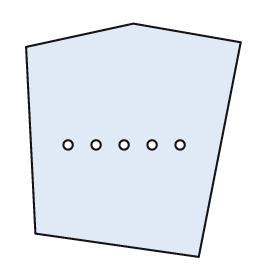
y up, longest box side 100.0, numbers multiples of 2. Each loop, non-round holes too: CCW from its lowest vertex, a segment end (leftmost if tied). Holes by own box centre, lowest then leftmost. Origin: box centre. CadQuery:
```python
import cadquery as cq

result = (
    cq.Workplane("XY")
    .moveTo(28.0, -50.0)
    .lineTo(46.0, 42.0)
    .lineTo(0.0, 50.0)
    .lineTo(-46.0, 40.0)
    .lineTo(-42.0, -40.0)
    .close()
    .moveTo(-28.0, -2.0)
    .circle(2.0)
    .moveTo(-16.0, -2.0)
    .circle(2.0)
    .moveTo(-4.0, -2.0)
    .circle(2.0)
    .moveTo(8.0, -2.0)
    .circle(2.0)
    .moveTo(20.0, -2.0)
    .circle(2.0)
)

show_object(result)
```